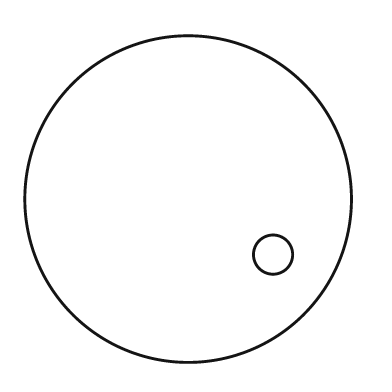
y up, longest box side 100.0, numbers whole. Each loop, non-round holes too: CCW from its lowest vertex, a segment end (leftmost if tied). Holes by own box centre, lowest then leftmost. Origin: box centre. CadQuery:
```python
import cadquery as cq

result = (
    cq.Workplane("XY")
    .moveTo(0.0, 0.0)
    .circle(50.0)
    .moveTo(26.0, -17.0)
    .circle(6.0)
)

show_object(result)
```